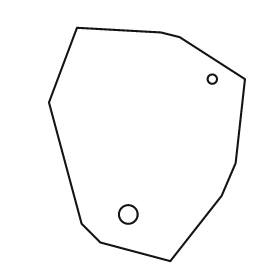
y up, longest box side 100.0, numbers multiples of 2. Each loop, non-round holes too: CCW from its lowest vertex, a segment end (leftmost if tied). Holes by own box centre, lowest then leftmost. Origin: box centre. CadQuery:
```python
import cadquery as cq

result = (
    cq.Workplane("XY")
    .moveTo(10.0, -50.0)
    .lineTo(32.0, -22.0)
    .lineTo(38.0, -8.0)
    .lineTo(42.0, 28.0)
    .lineTo(14.0, 46.0)
    .lineTo(6.0, 48.0)
    .lineTo(-30.0, 50.0)
    .lineTo(-42.0, 18.0)
    .lineTo(-28.0, -34.0)
    .lineTo(-20.0, -42.0)
    .close()
    .moveTo(-8.0, -30.0)
    .circle(4.0)
    .moveTo(28.0, 28.0)
    .circle(2.0)
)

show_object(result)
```